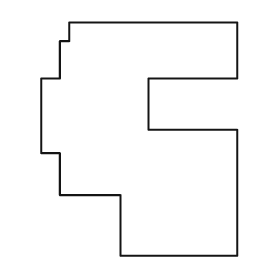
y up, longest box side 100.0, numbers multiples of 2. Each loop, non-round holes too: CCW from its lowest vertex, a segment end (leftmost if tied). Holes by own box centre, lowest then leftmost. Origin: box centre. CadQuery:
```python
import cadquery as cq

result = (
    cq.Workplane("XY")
    .moveTo(-8.0, -50.0)
    .lineTo(42.0, -50.0)
    .lineTo(42.0, 4.0)
    .lineTo(4.0, 4.0)
    .lineTo(4.0, 26.0)
    .lineTo(42.0, 26.0)
    .lineTo(42.0, 50.0)
    .lineTo(-30.0, 50.0)
    .lineTo(-30.0, 42.0)
    .lineTo(-34.0, 42.0)
    .lineTo(-34.0, 26.0)
    .lineTo(-42.0, 26.0)
    .lineTo(-42.0, -6.0)
    .lineTo(-34.0, -6.0)
    .lineTo(-34.0, -24.0)
    .lineTo(-8.0, -24.0)
    .close()
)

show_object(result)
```